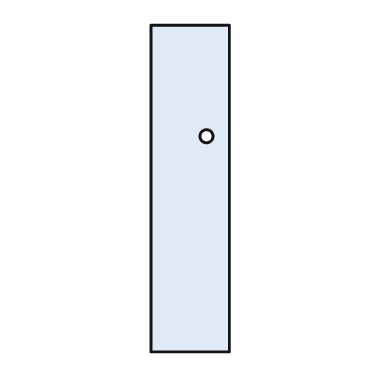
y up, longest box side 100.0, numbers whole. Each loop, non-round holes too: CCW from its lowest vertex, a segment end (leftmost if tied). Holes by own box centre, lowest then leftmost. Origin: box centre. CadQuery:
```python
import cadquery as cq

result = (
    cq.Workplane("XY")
    .moveTo(-12.0, -50.0)
    .lineTo(12.0, -50.0)
    .lineTo(12.0, 50.0)
    .lineTo(-12.0, 50.0)
    .close()
    .moveTo(5.0, 16.0)
    .circle(2.0)
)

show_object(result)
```